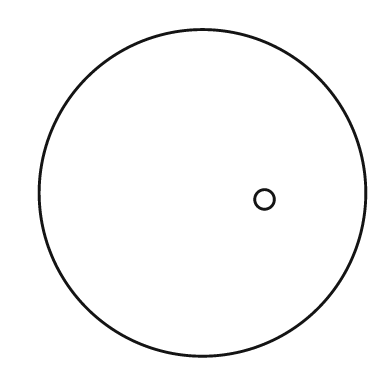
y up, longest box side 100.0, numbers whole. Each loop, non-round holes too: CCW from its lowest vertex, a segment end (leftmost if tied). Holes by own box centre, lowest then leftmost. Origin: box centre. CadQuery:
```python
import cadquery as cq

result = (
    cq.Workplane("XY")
    .moveTo(0.0, 0.0)
    .circle(50.0)
    .moveTo(19.0, -2.0)
    .circle(3.0)
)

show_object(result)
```